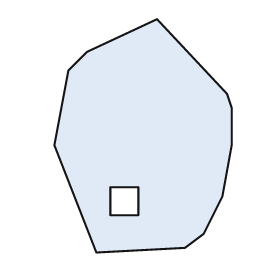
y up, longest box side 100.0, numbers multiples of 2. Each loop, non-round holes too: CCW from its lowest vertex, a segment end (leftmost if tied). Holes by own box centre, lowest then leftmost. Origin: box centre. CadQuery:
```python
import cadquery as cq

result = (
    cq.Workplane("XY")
    .moveTo(-20.0, -50.0)
    .lineTo(18.0, -48.0)
    .lineTo(26.0, -42.0)
    .lineTo(34.0, -26.0)
    .lineTo(38.0, -4.0)
    .lineTo(38.0, 12.0)
    .lineTo(36.0, 18.0)
    .lineTo(6.0, 50.0)
    .lineTo(-24.0, 36.0)
    .lineTo(-32.0, 28.0)
    .lineTo(-38.0, -4.0)
    .close()
    .moveTo(-14.0, -34.0)
    .lineTo(-2.0, -34.0)
    .lineTo(-2.0, -22.0)
    .lineTo(-14.0, -22.0)
    .close()
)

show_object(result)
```